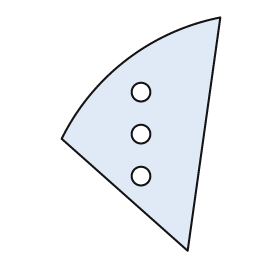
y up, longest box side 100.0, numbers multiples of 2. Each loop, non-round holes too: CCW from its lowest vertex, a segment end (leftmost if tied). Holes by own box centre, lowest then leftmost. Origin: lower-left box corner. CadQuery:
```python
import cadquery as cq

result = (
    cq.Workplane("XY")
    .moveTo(54.0, 0.0)
    .lineTo(68.0, 100.0)
    .threePointArc((28.0, 82.0), (0.0, 48.0))
    .close()
    .moveTo(34.0, 32.0)
    .circle(4.0)
    .moveTo(34.0, 50.0)
    .circle(4.0)
    .moveTo(34.0, 68.0)
    .circle(4.0)
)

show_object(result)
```